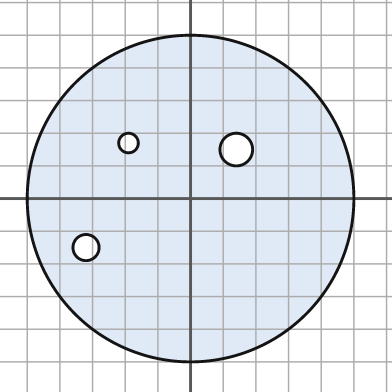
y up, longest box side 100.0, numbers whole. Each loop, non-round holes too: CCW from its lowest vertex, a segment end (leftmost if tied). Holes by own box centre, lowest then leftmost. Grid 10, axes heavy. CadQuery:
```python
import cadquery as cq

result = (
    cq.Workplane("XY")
    .moveTo(0.0, 0.0)
    .circle(50.0)
    .moveTo(-32.0, -15.0)
    .circle(4.0)
    .moveTo(14.0, 15.0)
    .circle(5.0)
    .moveTo(-19.0, 17.0)
    .circle(3.0)
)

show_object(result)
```